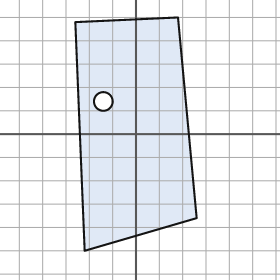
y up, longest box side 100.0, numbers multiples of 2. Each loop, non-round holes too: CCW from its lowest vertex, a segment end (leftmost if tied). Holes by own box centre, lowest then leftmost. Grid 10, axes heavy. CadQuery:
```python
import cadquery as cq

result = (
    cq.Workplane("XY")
    .moveTo(-22.0, -50.0)
    .lineTo(26.0, -36.0)
    .lineTo(18.0, 50.0)
    .lineTo(-26.0, 48.0)
    .close()
    .moveTo(-14.0, 14.0)
    .circle(4.0)
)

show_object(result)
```